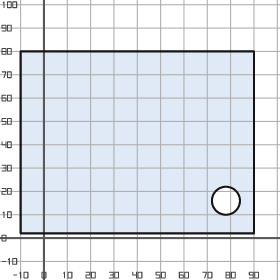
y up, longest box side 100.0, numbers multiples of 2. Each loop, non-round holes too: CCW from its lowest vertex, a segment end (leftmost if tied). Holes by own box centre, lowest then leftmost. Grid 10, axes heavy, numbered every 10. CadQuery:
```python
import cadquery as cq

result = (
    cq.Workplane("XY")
    .moveTo(-10.0, 2.0)
    .lineTo(90.0, 2.0)
    .lineTo(90.0, 80.0)
    .lineTo(-10.0, 80.0)
    .close()
    .moveTo(78.0, 16.0)
    .circle(6.0)
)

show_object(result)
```